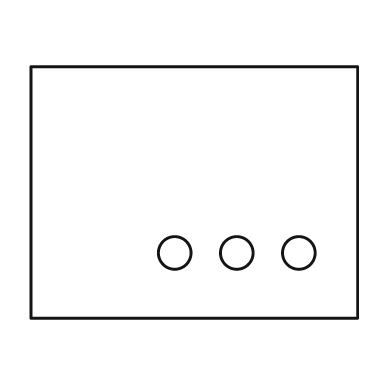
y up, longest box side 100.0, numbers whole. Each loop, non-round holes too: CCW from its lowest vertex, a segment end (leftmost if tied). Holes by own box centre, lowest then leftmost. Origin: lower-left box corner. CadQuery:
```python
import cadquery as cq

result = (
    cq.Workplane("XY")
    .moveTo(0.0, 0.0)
    .lineTo(100.0, 0.0)
    .lineTo(100.0, 77.0)
    .lineTo(0.0, 77.0)
    .close()
    .moveTo(44.0, 20.0)
    .circle(5.0)
    .moveTo(63.0, 20.0)
    .circle(5.0)
    .moveTo(82.0, 20.0)
    .circle(5.0)
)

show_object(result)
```